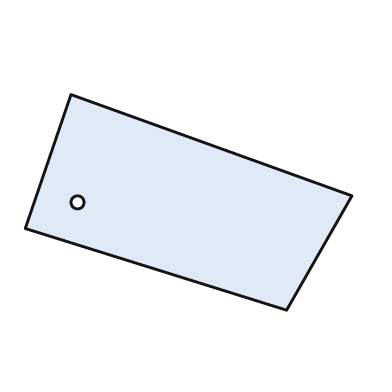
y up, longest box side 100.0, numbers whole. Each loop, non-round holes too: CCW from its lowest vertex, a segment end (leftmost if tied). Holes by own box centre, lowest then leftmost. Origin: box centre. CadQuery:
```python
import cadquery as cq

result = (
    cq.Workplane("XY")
    .moveTo(30.0, -33.0)
    .lineTo(50.0, 2.0)
    .lineTo(-36.0, 33.0)
    .lineTo(-50.0, -8.0)
    .close()
    .moveTo(-34.0, 0.0)
    .circle(2.0)
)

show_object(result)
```